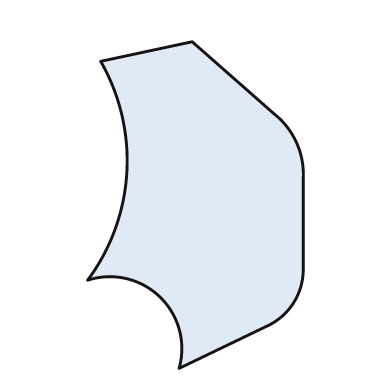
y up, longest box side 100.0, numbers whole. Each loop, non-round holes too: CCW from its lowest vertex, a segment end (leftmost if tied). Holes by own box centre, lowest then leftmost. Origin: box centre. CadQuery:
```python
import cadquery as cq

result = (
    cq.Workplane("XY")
    .moveTo(-5.0, -50.0)
    .lineTo(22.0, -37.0)
    .threePointArc((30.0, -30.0), (33.0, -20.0))
    .lineTo(33.0, 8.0)
    .threePointArc((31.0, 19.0), (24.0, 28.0))
    .lineTo(-1.0, 50.0)
    .lineTo(-29.0, 44.0)
    .threePointArc((-21.0, 10.0), (-33.0, -23.0))
    .threePointArc((-11.0, -28.0), (-5.0, -50.0))
    .close()
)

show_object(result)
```